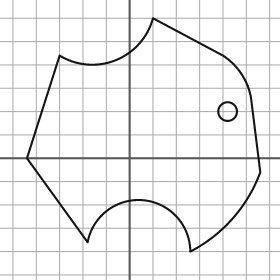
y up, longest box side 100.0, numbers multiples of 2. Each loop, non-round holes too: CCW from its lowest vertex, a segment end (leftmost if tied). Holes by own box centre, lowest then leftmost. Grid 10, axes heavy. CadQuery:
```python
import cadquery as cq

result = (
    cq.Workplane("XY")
    .moveTo(26.0, -40.0)
    .threePointArc((44.0, -26.0), (56.0, -6.0))
    .lineTo(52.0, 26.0)
    .threePointArc((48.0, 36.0), (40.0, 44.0))
    .lineTo(10.0, 60.0)
    .threePointArc((-6.0, 42.0), (-30.0, 44.0))
    .lineTo(-44.0, 0.0)
    .lineTo(-18.0, -36.0)
    .threePointArc((6.0, -18.0), (26.0, -40.0))
    .close()
    .moveTo(42.0, 20.0)
    .circle(4.0)
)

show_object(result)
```